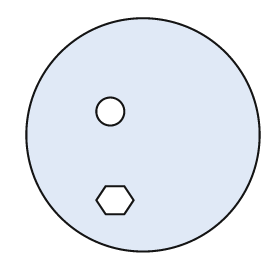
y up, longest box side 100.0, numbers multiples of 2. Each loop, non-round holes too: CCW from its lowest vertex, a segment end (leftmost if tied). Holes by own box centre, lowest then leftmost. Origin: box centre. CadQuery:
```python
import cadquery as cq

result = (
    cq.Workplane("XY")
    .moveTo(0.0, 0.0)
    .circle(50.0)
    .moveTo(-16.0, -34.0)
    .lineTo(-8.0, -34.0)
    .lineTo(-4.0, -28.0)
    .lineTo(-8.0, -22.0)
    .lineTo(-16.0, -22.0)
    .lineTo(-20.0, -28.0)
    .close()
    .moveTo(-14.0, 10.0)
    .circle(6.0)
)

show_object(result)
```